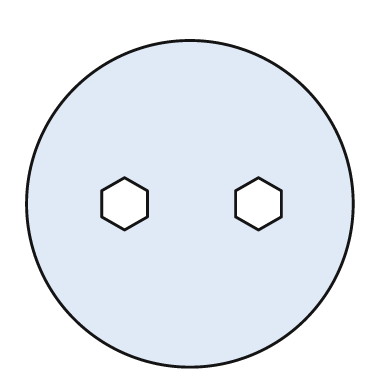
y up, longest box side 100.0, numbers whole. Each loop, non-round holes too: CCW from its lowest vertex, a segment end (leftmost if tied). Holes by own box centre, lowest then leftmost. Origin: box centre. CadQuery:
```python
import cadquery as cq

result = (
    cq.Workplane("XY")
    .moveTo(0.0, 0.0)
    .circle(50.0)
    .moveTo(-20.0, -8.0)
    .lineTo(-13.0, -4.0)
    .lineTo(-13.0, 4.0)
    .lineTo(-20.0, 8.0)
    .lineTo(-27.0, 4.0)
    .lineTo(-27.0, -4.0)
    .close()
    .moveTo(21.0, -8.0)
    .lineTo(28.0, -4.0)
    .lineTo(28.0, 4.0)
    .lineTo(21.0, 8.0)
    .lineTo(14.0, 4.0)
    .lineTo(14.0, -4.0)
    .close()
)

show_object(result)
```